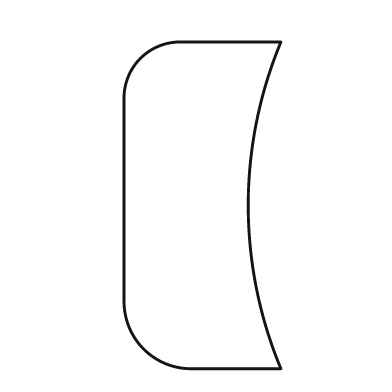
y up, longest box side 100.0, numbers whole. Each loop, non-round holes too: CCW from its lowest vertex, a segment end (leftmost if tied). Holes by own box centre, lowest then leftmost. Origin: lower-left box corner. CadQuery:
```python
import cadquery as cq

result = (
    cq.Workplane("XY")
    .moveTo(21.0, 0.0)
    .lineTo(48.0, 0.0)
    .threePointArc((38.0, 50.0), (48.0, 100.0))
    .lineTo(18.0, 100.0)
    .threePointArc((5.0, 95.0), (0.0, 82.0))
    .lineTo(0.0, 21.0)
    .threePointArc((6.0, 6.0), (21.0, 0.0))
    .close()
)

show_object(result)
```